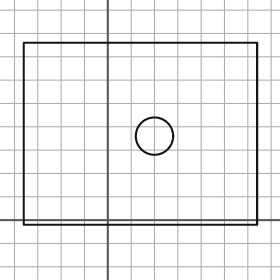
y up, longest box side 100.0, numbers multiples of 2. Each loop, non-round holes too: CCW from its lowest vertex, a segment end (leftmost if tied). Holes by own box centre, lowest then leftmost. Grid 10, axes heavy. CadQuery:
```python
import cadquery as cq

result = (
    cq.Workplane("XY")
    .moveTo(-36.0, -2.0)
    .lineTo(64.0, -2.0)
    .lineTo(64.0, 76.0)
    .lineTo(-36.0, 76.0)
    .close()
    .moveTo(20.0, 36.0)
    .circle(8.0)
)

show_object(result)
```